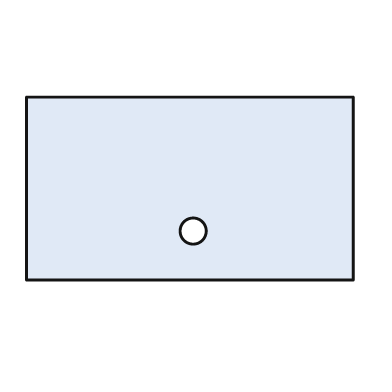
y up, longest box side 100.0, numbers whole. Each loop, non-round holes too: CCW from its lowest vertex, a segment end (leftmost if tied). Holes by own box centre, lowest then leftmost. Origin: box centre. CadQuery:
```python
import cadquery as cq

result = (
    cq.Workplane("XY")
    .moveTo(-50.0, -28.0)
    .lineTo(50.0, -28.0)
    .lineTo(50.0, 28.0)
    .lineTo(-50.0, 28.0)
    .close()
    .moveTo(1.0, -13.0)
    .circle(4.0)
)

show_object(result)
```